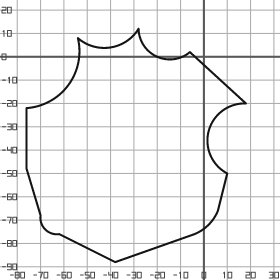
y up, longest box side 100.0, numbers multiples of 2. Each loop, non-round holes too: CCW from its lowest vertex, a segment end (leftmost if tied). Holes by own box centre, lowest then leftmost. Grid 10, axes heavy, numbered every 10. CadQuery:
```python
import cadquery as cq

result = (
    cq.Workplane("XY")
    .moveTo(-38.0, -88.0)
    .lineTo(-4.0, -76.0)
    .threePointArc((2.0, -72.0), (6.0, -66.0))
    .lineTo(10.0, -50.0)
    .threePointArc((2.0, -32.0), (18.0, -20.0))
    .lineTo(-6.0, 2.0)
    .threePointArc((-20.0, 0.0), (-28.0, 12.0))
    .threePointArc((-40.0, 4.0), (-54.0, 8.0))
    .threePointArc((-58.0, -12.0), (-76.0, -22.0))
    .lineTo(-76.0, -48.0)
    .lineTo(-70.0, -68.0)
    .threePointArc((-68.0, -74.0), (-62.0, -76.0))
    .close()
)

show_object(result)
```